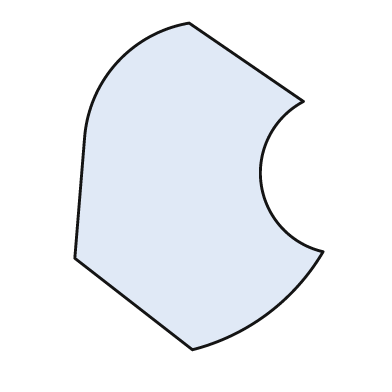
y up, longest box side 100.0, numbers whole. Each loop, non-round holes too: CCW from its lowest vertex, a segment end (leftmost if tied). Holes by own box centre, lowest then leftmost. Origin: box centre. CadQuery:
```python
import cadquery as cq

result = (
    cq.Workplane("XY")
    .moveTo(-2.0, -50.0)
    .threePointArc((21.0, -39.0), (38.0, -20.0))
    .threePointArc((19.0, 1.0), (32.0, 26.0))
    .lineTo(-3.0, 50.0)
    .threePointArc((-25.0, 38.0), (-35.0, 15.0))
    .lineTo(-38.0, -22.0)
    .close()
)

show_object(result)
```